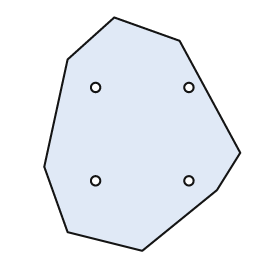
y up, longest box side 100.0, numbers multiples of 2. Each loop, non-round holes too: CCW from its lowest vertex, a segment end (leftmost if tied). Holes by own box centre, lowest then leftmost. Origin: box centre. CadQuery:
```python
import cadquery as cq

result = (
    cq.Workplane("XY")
    .moveTo(0.0, -50.0)
    .lineTo(32.0, -24.0)
    .lineTo(42.0, -8.0)
    .lineTo(16.0, 40.0)
    .lineTo(-12.0, 50.0)
    .lineTo(-32.0, 32.0)
    .lineTo(-42.0, -14.0)
    .lineTo(-32.0, -42.0)
    .close()
    .moveTo(-20.0, -20.0)
    .circle(2.0)
    .moveTo(20.0, -20.0)
    .circle(2.0)
    .moveTo(-20.0, 20.0)
    .circle(2.0)
    .moveTo(20.0, 20.0)
    .circle(2.0)
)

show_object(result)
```